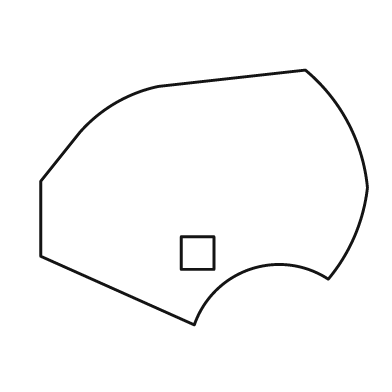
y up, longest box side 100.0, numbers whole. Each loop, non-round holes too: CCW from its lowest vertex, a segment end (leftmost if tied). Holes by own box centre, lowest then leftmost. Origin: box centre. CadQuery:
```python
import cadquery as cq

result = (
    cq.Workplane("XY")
    .moveTo(-3.0, -39.0)
    .threePointArc((14.0, -22.0), (38.0, -25.0))
    .threePointArc((46.0, -12.0), (50.0, 3.0))
    .threePointArc((44.0, 23.0), (31.0, 39.0))
    .lineTo(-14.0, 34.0)
    .threePointArc((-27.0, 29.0), (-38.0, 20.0))
    .lineTo(-50.0, 5.0)
    .lineTo(-50.0, -18.0)
    .close()
    .moveTo(-7.0, -22.0)
    .lineTo(3.0, -22.0)
    .lineTo(3.0, -12.0)
    .lineTo(-7.0, -12.0)
    .close()
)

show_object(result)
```